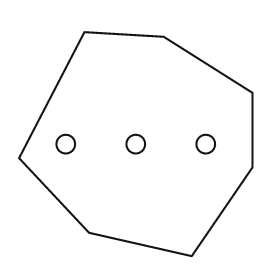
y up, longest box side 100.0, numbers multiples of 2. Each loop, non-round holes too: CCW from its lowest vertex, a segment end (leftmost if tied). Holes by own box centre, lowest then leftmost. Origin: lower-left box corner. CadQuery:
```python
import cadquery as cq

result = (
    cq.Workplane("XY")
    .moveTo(74.0, 0.0)
    .lineTo(100.0, 38.0)
    .lineTo(100.0, 70.0)
    .lineTo(62.0, 94.0)
    .lineTo(28.0, 96.0)
    .lineTo(0.0, 42.0)
    .lineTo(30.0, 10.0)
    .close()
    .moveTo(20.0, 48.0)
    .circle(4.0)
    .moveTo(50.0, 48.0)
    .circle(4.0)
    .moveTo(80.0, 48.0)
    .circle(4.0)
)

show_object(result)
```